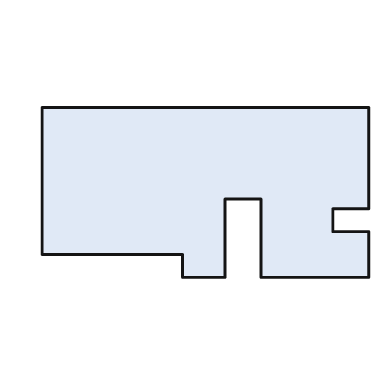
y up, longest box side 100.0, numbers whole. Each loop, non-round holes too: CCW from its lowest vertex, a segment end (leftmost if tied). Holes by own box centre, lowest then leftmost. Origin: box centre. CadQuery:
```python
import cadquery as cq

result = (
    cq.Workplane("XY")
    .moveTo(-7.0, -26.0)
    .lineTo(6.0, -26.0)
    .lineTo(6.0, -2.0)
    .lineTo(17.0, -2.0)
    .lineTo(17.0, -26.0)
    .lineTo(50.0, -26.0)
    .lineTo(50.0, -12.0)
    .lineTo(39.0, -12.0)
    .lineTo(39.0, -5.0)
    .lineTo(50.0, -5.0)
    .lineTo(50.0, 26.0)
    .lineTo(-50.0, 26.0)
    .lineTo(-50.0, -19.0)
    .lineTo(-7.0, -19.0)
    .close()
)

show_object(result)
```